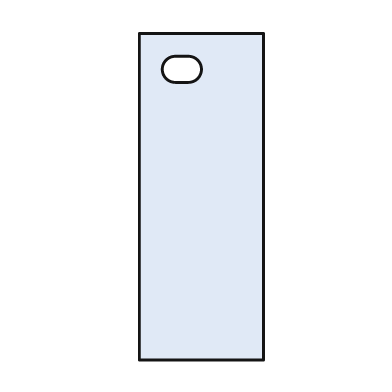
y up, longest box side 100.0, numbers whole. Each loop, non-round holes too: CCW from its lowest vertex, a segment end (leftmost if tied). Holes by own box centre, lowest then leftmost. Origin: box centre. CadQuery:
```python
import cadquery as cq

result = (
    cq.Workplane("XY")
    .moveTo(-19.0, -50.0)
    .lineTo(19.0, -50.0)
    .lineTo(19.0, 50.0)
    .lineTo(-19.0, 50.0)
    .close()
    .moveTo(-8.0, 35.0)
    .lineTo(-4.0, 35.0)
    .threePointArc((0.0, 39.0), (-4.0, 43.0))
    .lineTo(-8.0, 43.0)
    .threePointArc((-12.0, 39.0), (-8.0, 35.0))
    .close()
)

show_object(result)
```